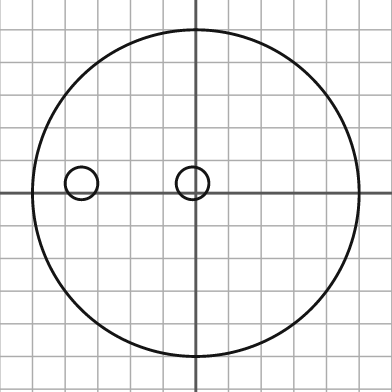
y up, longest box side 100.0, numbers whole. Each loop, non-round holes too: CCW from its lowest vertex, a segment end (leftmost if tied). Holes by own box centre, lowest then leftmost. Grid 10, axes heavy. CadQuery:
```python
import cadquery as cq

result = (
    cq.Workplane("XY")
    .moveTo(0.0, 0.0)
    .circle(50.0)
    .moveTo(-35.0, 3.0)
    .circle(5.0)
    .moveTo(-1.0, 3.0)
    .circle(5.0)
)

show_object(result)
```